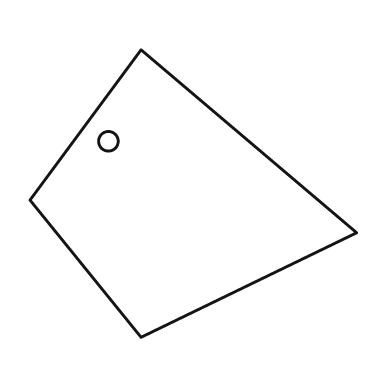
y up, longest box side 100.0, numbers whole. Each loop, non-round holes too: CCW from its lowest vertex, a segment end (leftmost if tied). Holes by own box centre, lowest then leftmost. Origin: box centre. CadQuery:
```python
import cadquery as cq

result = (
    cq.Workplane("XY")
    .moveTo(-16.0, -44.0)
    .lineTo(50.0, -12.0)
    .lineTo(-16.0, 44.0)
    .lineTo(-50.0, -2.0)
    .close()
    .moveTo(-26.0, 16.0)
    .circle(3.0)
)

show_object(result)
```